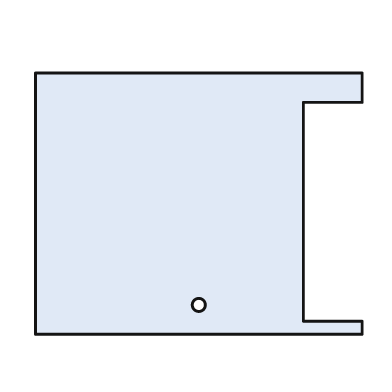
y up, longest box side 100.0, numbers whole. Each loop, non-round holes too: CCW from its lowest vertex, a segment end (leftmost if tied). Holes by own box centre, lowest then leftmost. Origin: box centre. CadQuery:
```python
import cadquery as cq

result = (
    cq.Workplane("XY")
    .moveTo(-50.0, -40.0)
    .lineTo(50.0, -40.0)
    .lineTo(50.0, -36.0)
    .lineTo(32.0, -36.0)
    .lineTo(32.0, 31.0)
    .lineTo(50.0, 31.0)
    .lineTo(50.0, 40.0)
    .lineTo(-50.0, 40.0)
    .close()
    .moveTo(0.0, -31.0)
    .circle(2.0)
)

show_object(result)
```